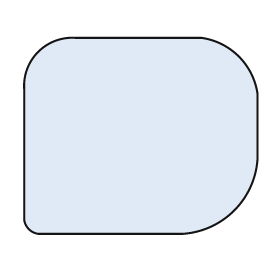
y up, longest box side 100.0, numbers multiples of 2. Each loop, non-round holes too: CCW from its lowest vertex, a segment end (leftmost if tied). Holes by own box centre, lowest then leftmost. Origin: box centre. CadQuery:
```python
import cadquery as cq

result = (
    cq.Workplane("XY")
    .moveTo(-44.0, -42.0)
    .lineTo(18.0, -42.0)
    .threePointArc((40.0, -32.0), (50.0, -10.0))
    .lineTo(50.0, 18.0)
    .threePointArc((42.0, 34.0), (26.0, 42.0))
    .lineTo(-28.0, 42.0)
    .threePointArc((-44.0, 36.0), (-50.0, 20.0))
    .lineTo(-50.0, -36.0)
    .threePointArc((-48.0, -40.0), (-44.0, -42.0))
    .close()
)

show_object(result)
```